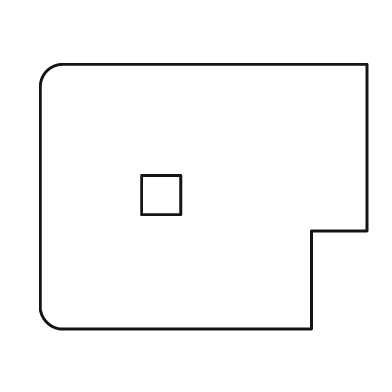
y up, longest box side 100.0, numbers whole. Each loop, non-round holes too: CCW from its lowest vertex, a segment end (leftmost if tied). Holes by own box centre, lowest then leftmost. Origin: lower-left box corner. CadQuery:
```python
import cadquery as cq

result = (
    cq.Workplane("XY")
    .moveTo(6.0, 0.0)
    .lineTo(83.0, 0.0)
    .lineTo(83.0, 30.0)
    .lineTo(100.0, 30.0)
    .lineTo(100.0, 81.0)
    .lineTo(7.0, 81.0)
    .threePointArc((2.0, 79.0), (0.0, 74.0))
    .lineTo(0.0, 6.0)
    .threePointArc((2.0, 2.0), (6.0, 0.0))
    .close()
    .moveTo(31.0, 35.0)
    .lineTo(43.0, 35.0)
    .lineTo(43.0, 47.0)
    .lineTo(31.0, 47.0)
    .close()
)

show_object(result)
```